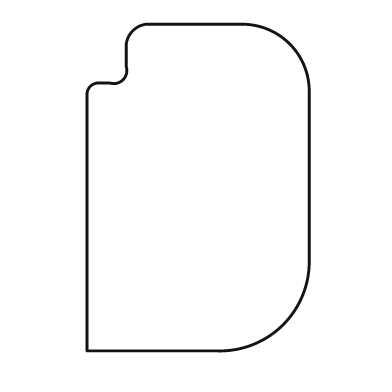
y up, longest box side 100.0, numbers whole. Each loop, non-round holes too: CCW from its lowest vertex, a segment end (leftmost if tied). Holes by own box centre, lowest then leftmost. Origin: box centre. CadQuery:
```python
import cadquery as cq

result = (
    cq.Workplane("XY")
    .moveTo(-34.0, -50.0)
    .lineTo(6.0, -50.0)
    .threePointArc((26.0, -42.0), (34.0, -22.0))
    .lineTo(34.0, 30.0)
    .threePointArc((28.0, 44.0), (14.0, 50.0))
    .lineTo(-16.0, 50.0)
    .threePointArc((-20.0, 48.0), (-22.0, 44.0))
    .lineTo(-22.0, 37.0)
    .threePointArc((-23.0, 33.0), (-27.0, 32.0))
    .lineTo(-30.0, 32.0)
    .threePointArc((-33.0, 31.0), (-34.0, 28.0))
    .close()
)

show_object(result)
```